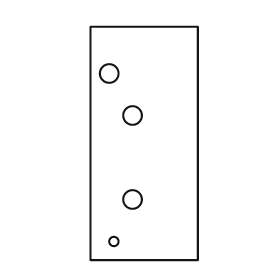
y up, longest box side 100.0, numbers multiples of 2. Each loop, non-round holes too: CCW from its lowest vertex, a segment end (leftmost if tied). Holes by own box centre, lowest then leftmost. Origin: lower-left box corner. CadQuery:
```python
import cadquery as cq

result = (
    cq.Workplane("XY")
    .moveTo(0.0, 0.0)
    .lineTo(46.0, 0.0)
    .lineTo(46.0, 100.0)
    .lineTo(0.0, 100.0)
    .close()
    .moveTo(10.0, 8.0)
    .circle(2.0)
    .moveTo(18.0, 26.0)
    .circle(4.0)
    .moveTo(18.0, 62.0)
    .circle(4.0)
    .moveTo(8.0, 80.0)
    .circle(4.0)
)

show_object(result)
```